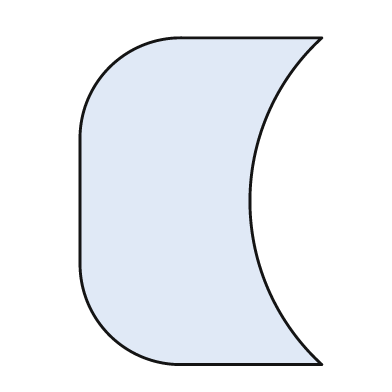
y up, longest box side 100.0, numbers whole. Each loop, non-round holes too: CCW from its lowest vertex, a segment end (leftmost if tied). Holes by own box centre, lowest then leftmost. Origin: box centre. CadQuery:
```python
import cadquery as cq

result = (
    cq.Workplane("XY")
    .moveTo(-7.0, -50.0)
    .lineTo(37.0, -50.0)
    .threePointArc((15.0, 0.0), (37.0, 50.0))
    .lineTo(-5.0, 50.0)
    .threePointArc((-28.0, 41.0), (-37.0, 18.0))
    .lineTo(-37.0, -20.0)
    .threePointArc((-28.0, -41.0), (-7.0, -50.0))
    .close()
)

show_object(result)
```